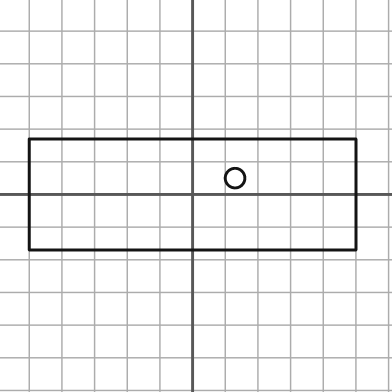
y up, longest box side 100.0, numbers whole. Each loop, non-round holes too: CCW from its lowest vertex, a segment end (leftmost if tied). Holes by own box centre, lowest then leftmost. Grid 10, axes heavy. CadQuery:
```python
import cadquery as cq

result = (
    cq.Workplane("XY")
    .moveTo(-50.0, -17.0)
    .lineTo(50.0, -17.0)
    .lineTo(50.0, 17.0)
    .lineTo(-50.0, 17.0)
    .close()
    .moveTo(13.0, 5.0)
    .circle(3.0)
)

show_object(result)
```